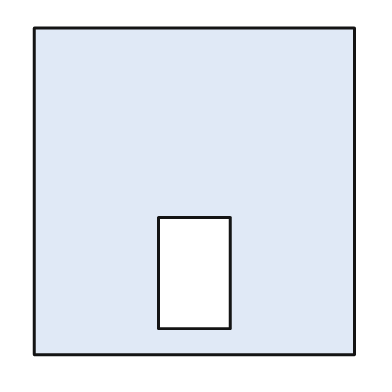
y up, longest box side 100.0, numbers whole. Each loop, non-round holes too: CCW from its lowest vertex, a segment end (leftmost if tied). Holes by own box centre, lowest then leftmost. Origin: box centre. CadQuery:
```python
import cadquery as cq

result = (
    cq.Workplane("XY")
    .moveTo(-49.0, -50.0)
    .lineTo(49.0, -50.0)
    .lineTo(49.0, 50.0)
    .lineTo(-49.0, 50.0)
    .close()
    .moveTo(-11.0, -42.0)
    .lineTo(11.0, -42.0)
    .lineTo(11.0, -8.0)
    .lineTo(-11.0, -8.0)
    .close()
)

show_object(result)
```